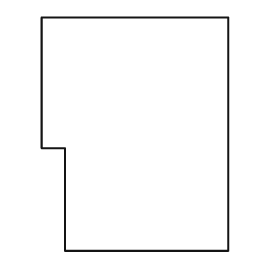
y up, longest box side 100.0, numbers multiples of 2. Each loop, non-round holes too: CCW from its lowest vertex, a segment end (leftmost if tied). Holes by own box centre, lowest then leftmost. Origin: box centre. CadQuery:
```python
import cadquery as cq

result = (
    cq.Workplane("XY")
    .moveTo(-30.0, -50.0)
    .lineTo(40.0, -50.0)
    .lineTo(40.0, 50.0)
    .lineTo(-40.0, 50.0)
    .lineTo(-40.0, -6.0)
    .lineTo(-30.0, -6.0)
    .close()
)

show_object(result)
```